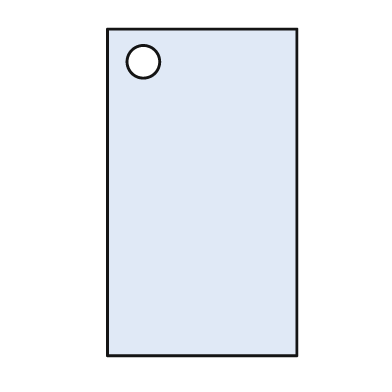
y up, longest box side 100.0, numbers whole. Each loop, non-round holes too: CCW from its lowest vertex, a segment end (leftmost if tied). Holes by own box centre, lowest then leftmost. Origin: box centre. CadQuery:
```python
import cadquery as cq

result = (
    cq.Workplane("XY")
    .moveTo(-29.0, -50.0)
    .lineTo(29.0, -50.0)
    .lineTo(29.0, 50.0)
    .lineTo(-29.0, 50.0)
    .close()
    .moveTo(-18.0, 40.0)
    .circle(5.0)
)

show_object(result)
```